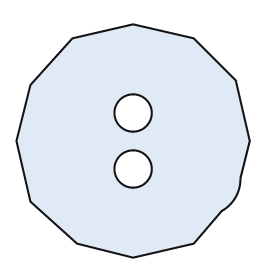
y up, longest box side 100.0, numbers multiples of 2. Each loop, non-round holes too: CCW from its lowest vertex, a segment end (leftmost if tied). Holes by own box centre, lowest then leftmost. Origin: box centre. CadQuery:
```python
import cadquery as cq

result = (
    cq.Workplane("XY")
    .moveTo(0.0, -50.0)
    .lineTo(26.0, -44.0)
    .lineTo(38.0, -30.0)
    .threePointArc((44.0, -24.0), (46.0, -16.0))
    .lineTo(50.0, 0.0)
    .lineTo(44.0, 26.0)
    .lineTo(26.0, 44.0)
    .lineTo(0.0, 50.0)
    .lineTo(-26.0, 44.0)
    .lineTo(-44.0, 24.0)
    .lineTo(-50.0, 0.0)
    .lineTo(-44.0, -26.0)
    .lineTo(-24.0, -44.0)
    .close()
    .moveTo(0.0, -12.0)
    .circle(8.0)
    .moveTo(0.0, 12.0)
    .circle(8.0)
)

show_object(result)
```